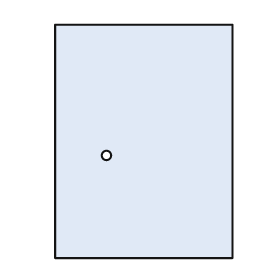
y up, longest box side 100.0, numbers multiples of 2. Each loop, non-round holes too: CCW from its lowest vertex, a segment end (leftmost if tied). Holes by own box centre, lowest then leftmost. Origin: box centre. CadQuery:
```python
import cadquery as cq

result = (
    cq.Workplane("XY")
    .moveTo(-38.0, -50.0)
    .lineTo(38.0, -50.0)
    .lineTo(38.0, 50.0)
    .lineTo(-38.0, 50.0)
    .close()
    .moveTo(-16.0, -6.0)
    .circle(2.0)
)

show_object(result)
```